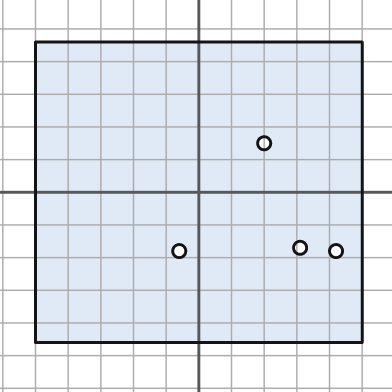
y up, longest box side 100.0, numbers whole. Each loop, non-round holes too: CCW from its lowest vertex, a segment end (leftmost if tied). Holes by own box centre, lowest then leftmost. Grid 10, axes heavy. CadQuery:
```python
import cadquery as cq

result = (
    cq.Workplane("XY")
    .moveTo(-50.0, -46.0)
    .lineTo(50.0, -46.0)
    .lineTo(50.0, 46.0)
    .lineTo(-50.0, 46.0)
    .close()
    .moveTo(-6.0, -18.0)
    .circle(2.0)
    .moveTo(42.0, -18.0)
    .circle(2.0)
    .moveTo(31.0, -17.0)
    .circle(2.0)
    .moveTo(20.0, 15.0)
    .circle(2.0)
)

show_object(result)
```